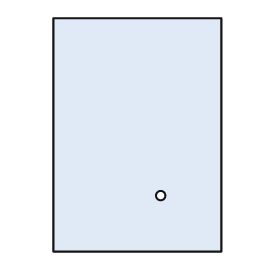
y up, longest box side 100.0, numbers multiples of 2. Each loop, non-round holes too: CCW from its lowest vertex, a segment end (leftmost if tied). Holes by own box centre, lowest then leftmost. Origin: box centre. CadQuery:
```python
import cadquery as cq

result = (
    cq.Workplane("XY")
    .moveTo(-36.0, -50.0)
    .lineTo(36.0, -50.0)
    .lineTo(36.0, 50.0)
    .lineTo(-36.0, 50.0)
    .close()
    .moveTo(10.0, -26.0)
    .circle(2.0)
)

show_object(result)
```